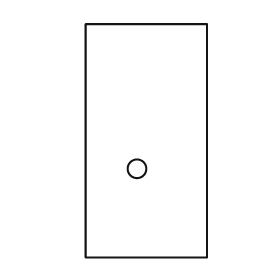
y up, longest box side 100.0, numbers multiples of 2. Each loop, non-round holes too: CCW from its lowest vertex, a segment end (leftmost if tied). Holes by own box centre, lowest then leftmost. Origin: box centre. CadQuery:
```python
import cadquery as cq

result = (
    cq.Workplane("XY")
    .moveTo(-26.0, -50.0)
    .lineTo(26.0, -50.0)
    .lineTo(26.0, 50.0)
    .lineTo(-26.0, 50.0)
    .close()
    .moveTo(-4.0, -12.0)
    .circle(4.0)
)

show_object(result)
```